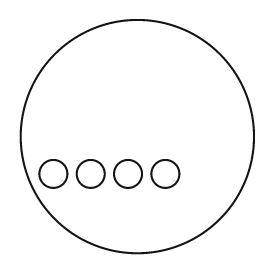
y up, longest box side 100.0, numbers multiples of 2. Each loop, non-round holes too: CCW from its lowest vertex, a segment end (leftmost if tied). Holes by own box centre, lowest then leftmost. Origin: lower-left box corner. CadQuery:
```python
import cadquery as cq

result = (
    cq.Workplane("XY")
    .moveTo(50.0, 50.0)
    .circle(50.0)
    .moveTo(14.0, 34.0)
    .circle(6.0)
    .moveTo(30.0, 34.0)
    .circle(6.0)
    .moveTo(46.0, 34.0)
    .circle(6.0)
    .moveTo(62.0, 34.0)
    .circle(6.0)
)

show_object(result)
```